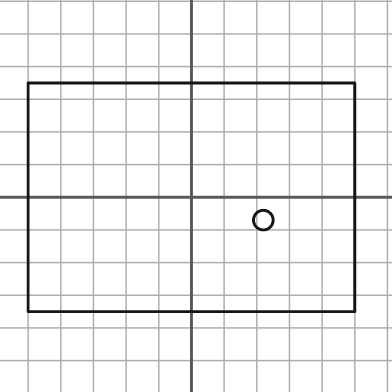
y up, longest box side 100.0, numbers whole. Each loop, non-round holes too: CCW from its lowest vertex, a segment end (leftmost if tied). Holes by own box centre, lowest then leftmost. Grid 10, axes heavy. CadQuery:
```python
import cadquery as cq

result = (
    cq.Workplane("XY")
    .moveTo(-50.0, -35.0)
    .lineTo(50.0, -35.0)
    .lineTo(50.0, 35.0)
    .lineTo(-50.0, 35.0)
    .close()
    .moveTo(22.0, -7.0)
    .circle(3.0)
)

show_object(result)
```